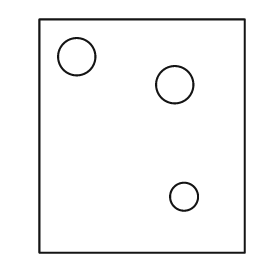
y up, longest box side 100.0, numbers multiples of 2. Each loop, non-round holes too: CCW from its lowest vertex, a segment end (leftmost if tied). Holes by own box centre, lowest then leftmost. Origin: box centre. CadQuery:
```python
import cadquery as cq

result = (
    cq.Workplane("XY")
    .moveTo(-44.0, -50.0)
    .lineTo(44.0, -50.0)
    .lineTo(44.0, 50.0)
    .lineTo(-44.0, 50.0)
    .close()
    .moveTo(18.0, -26.0)
    .circle(6.0)
    .moveTo(14.0, 22.0)
    .circle(8.0)
    .moveTo(-28.0, 34.0)
    .circle(8.0)
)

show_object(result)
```